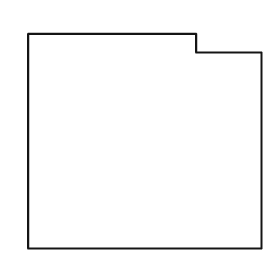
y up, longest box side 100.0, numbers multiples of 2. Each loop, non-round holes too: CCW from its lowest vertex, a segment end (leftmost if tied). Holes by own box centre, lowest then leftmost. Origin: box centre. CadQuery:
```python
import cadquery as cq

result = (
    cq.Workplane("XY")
    .moveTo(-50.0, -46.0)
    .lineTo(50.0, -46.0)
    .lineTo(50.0, 38.0)
    .lineTo(22.0, 38.0)
    .lineTo(22.0, 46.0)
    .lineTo(-50.0, 46.0)
    .close()
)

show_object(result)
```